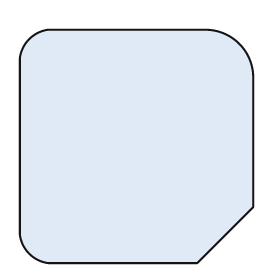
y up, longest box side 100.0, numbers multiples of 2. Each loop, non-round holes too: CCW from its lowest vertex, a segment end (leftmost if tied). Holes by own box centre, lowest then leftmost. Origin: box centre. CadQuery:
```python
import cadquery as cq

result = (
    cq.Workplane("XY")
    .moveTo(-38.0, -50.0)
    .lineTo(26.0, -50.0)
    .lineTo(50.0, -26.0)
    .lineTo(50.0, 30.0)
    .threePointArc((44.0, 44.0), (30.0, 50.0))
    .lineTo(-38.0, 50.0)
    .threePointArc((-46.0, 46.0), (-50.0, 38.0))
    .lineTo(-50.0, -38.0)
    .threePointArc((-46.0, -46.0), (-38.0, -50.0))
    .close()
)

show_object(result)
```